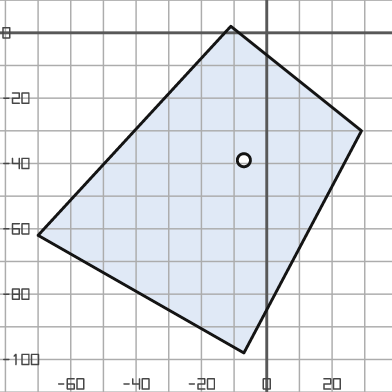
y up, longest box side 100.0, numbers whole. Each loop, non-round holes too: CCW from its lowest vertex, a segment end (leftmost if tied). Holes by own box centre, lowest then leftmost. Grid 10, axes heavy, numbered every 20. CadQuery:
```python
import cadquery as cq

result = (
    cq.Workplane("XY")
    .moveTo(-7.0, -98.0)
    .lineTo(29.0, -30.0)
    .lineTo(-11.0, 2.0)
    .lineTo(-70.0, -62.0)
    .close()
    .moveTo(-7.0, -39.0)
    .circle(2.0)
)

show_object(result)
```